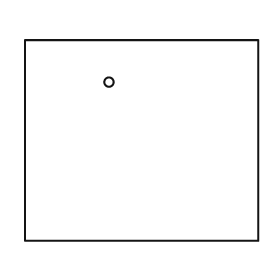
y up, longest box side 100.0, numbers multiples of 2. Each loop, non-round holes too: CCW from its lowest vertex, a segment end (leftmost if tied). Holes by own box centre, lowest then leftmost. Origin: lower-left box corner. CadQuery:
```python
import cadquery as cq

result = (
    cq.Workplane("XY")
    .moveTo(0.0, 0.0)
    .lineTo(100.0, 0.0)
    .lineTo(100.0, 86.0)
    .lineTo(0.0, 86.0)
    .close()
    .moveTo(36.0, 68.0)
    .circle(2.0)
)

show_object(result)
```